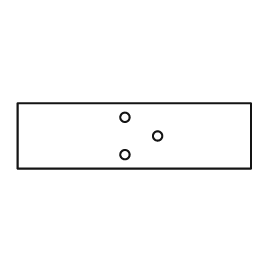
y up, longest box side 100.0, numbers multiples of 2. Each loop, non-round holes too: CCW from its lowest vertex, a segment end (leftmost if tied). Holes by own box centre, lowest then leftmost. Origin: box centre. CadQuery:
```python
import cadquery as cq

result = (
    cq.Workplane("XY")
    .moveTo(-50.0, -14.0)
    .lineTo(50.0, -14.0)
    .lineTo(50.0, 14.0)
    .lineTo(-50.0, 14.0)
    .close()
    .moveTo(-4.0, -8.0)
    .circle(2.0)
    .moveTo(10.0, 0.0)
    .circle(2.0)
    .moveTo(-4.0, 8.0)
    .circle(2.0)
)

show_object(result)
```